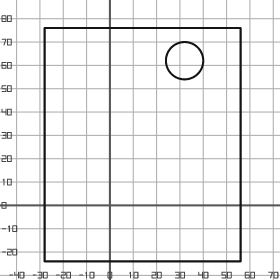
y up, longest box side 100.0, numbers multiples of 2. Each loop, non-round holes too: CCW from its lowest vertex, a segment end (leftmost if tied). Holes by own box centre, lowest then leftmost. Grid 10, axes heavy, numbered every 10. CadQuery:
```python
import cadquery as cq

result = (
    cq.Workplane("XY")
    .moveTo(-28.0, -24.0)
    .lineTo(56.0, -24.0)
    .lineTo(56.0, 76.0)
    .lineTo(-28.0, 76.0)
    .close()
    .moveTo(32.0, 62.0)
    .circle(8.0)
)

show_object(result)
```